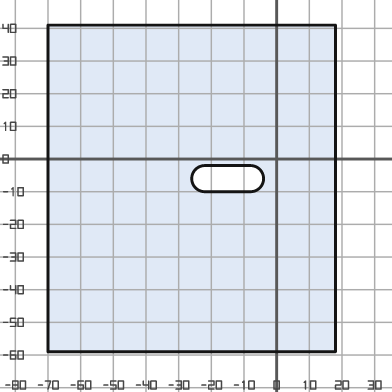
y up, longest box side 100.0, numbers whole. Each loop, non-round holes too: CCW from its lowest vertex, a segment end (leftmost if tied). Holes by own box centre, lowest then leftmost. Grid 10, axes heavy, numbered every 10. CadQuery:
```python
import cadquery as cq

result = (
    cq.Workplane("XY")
    .moveTo(-70.0, -59.0)
    .lineTo(18.0, -59.0)
    .lineTo(18.0, 41.0)
    .lineTo(-70.0, 41.0)
    .close()
    .moveTo(-22.0, -10.0)
    .lineTo(-8.0, -10.0)
    .threePointArc((-4.0, -6.0), (-8.0, -2.0))
    .lineTo(-22.0, -2.0)
    .threePointArc((-26.0, -6.0), (-22.0, -10.0))
    .close()
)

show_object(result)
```